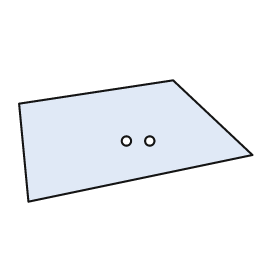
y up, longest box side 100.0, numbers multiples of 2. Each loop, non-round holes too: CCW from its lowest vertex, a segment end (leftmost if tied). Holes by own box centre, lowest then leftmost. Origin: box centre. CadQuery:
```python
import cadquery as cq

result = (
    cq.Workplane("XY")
    .moveTo(-46.0, -26.0)
    .lineTo(50.0, -6.0)
    .lineTo(16.0, 26.0)
    .lineTo(-50.0, 16.0)
    .close()
    .moveTo(-4.0, 0.0)
    .circle(2.0)
    .moveTo(6.0, 0.0)
    .circle(2.0)
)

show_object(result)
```